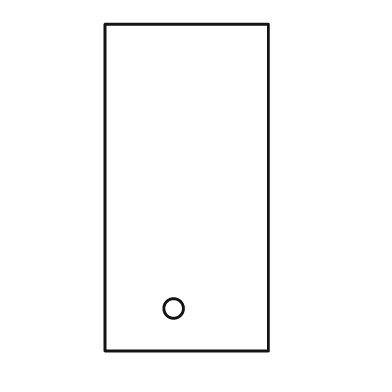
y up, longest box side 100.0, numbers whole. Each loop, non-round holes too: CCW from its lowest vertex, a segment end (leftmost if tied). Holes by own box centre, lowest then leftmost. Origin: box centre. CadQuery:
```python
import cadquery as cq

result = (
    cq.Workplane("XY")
    .moveTo(-25.0, -50.0)
    .lineTo(25.0, -50.0)
    .lineTo(25.0, 50.0)
    .lineTo(-25.0, 50.0)
    .close()
    .moveTo(-4.0, -37.0)
    .circle(3.0)
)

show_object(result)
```